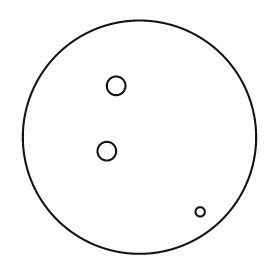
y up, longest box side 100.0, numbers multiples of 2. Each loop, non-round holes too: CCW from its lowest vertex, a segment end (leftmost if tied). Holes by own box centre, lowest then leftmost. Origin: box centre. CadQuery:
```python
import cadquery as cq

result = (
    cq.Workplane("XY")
    .moveTo(0.0, 0.0)
    .circle(50.0)
    .moveTo(26.0, -32.0)
    .circle(2.0)
    .moveTo(-14.0, -6.0)
    .circle(4.0)
    .moveTo(-10.0, 22.0)
    .circle(4.0)
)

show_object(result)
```